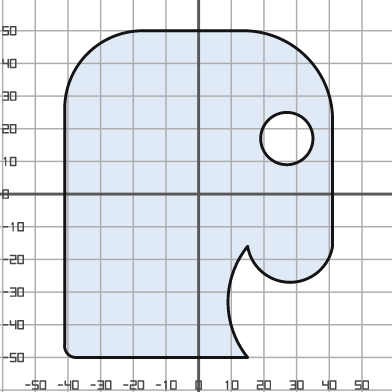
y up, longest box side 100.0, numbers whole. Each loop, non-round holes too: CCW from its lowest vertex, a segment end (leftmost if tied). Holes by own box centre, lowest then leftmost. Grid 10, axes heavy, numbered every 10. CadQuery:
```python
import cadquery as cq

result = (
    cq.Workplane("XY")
    .moveTo(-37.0, -50.0)
    .lineTo(15.0, -50.0)
    .threePointArc((9.0, -33.0), (15.0, -16.0))
    .threePointArc((28.0, -27.0), (41.0, -16.0))
    .lineTo(41.0, 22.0)
    .threePointArc((33.0, 42.0), (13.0, 50.0))
    .lineTo(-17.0, 50.0)
    .threePointArc((-34.0, 43.0), (-41.0, 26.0))
    .lineTo(-41.0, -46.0)
    .threePointArc((-40.0, -49.0), (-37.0, -50.0))
    .close()
    .moveTo(27.0, 17.0)
    .circle(8.0)
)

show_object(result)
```